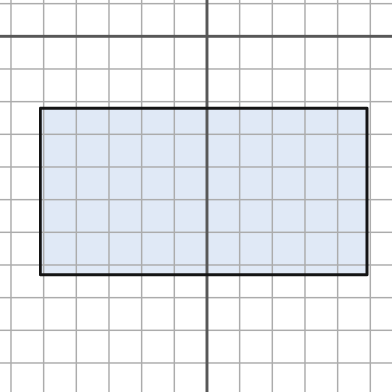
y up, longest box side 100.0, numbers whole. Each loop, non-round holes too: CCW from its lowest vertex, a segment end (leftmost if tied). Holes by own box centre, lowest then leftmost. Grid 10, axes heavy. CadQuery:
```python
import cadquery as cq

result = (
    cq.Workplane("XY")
    .moveTo(-51.0, -73.0)
    .lineTo(49.0, -73.0)
    .lineTo(49.0, -22.0)
    .lineTo(-51.0, -22.0)
    .close()
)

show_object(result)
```